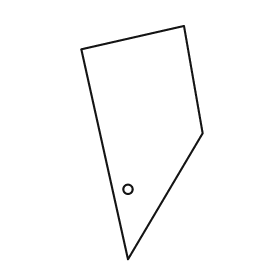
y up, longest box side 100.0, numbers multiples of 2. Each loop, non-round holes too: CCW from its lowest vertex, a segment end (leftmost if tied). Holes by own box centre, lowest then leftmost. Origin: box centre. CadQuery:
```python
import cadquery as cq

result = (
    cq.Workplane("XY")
    .moveTo(-6.0, -50.0)
    .lineTo(26.0, 4.0)
    .lineTo(18.0, 50.0)
    .lineTo(-26.0, 40.0)
    .close()
    .moveTo(-6.0, -20.0)
    .circle(2.0)
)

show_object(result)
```